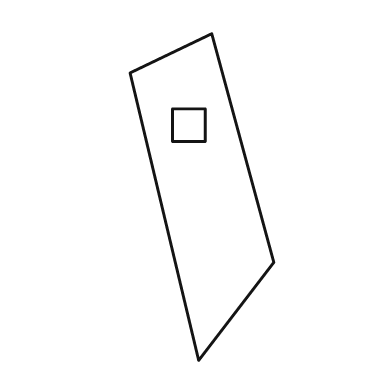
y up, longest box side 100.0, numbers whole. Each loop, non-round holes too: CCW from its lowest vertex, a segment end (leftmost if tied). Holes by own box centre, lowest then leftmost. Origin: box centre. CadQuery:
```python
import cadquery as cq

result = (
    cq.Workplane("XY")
    .moveTo(-1.0, -50.0)
    .lineTo(22.0, -20.0)
    .lineTo(3.0, 50.0)
    .lineTo(-22.0, 38.0)
    .close()
    .moveTo(-9.0, 17.0)
    .lineTo(1.0, 17.0)
    .lineTo(1.0, 27.0)
    .lineTo(-9.0, 27.0)
    .close()
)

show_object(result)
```